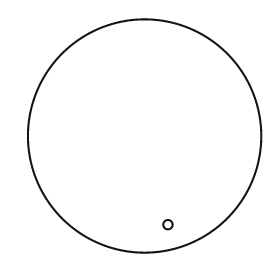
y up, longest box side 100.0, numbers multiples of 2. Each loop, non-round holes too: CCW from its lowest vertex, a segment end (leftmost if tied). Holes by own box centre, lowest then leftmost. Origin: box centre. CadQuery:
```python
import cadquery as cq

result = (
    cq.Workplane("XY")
    .moveTo(0.0, 0.0)
    .circle(50.0)
    .moveTo(10.0, -38.0)
    .circle(2.0)
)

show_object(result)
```